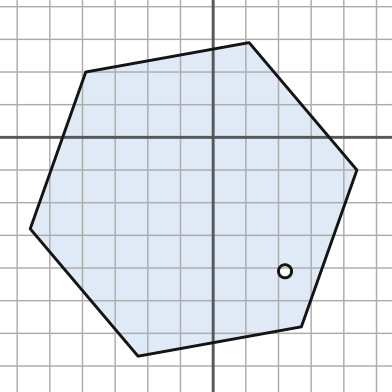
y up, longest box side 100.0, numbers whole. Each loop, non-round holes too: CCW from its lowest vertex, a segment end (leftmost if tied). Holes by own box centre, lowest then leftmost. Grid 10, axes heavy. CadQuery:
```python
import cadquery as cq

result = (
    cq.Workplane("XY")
    .moveTo(-23.0, -67.0)
    .lineTo(27.0, -58.0)
    .lineTo(44.0, -10.0)
    .lineTo(11.0, 29.0)
    .lineTo(-39.0, 20.0)
    .lineTo(-56.0, -28.0)
    .close()
    .moveTo(22.0, -41.0)
    .circle(2.0)
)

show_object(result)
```